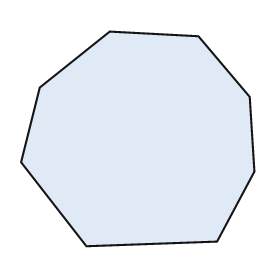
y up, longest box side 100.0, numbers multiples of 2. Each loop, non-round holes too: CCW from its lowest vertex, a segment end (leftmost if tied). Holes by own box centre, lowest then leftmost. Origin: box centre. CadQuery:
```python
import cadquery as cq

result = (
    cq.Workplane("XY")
    .moveTo(-22.0, -46.0)
    .lineTo(34.0, -44.0)
    .lineTo(50.0, -14.0)
    .lineTo(48.0, 18.0)
    .lineTo(26.0, 44.0)
    .lineTo(-12.0, 46.0)
    .lineTo(-42.0, 22.0)
    .lineTo(-50.0, -10.0)
    .close()
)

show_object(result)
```